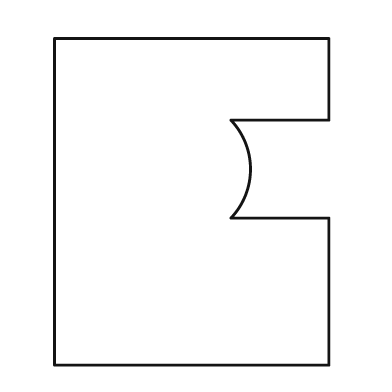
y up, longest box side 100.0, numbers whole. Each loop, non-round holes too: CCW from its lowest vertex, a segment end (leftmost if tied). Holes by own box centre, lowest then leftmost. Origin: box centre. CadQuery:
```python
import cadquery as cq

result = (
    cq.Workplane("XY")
    .moveTo(-42.0, -50.0)
    .lineTo(42.0, -50.0)
    .lineTo(42.0, -5.0)
    .lineTo(12.0, -5.0)
    .threePointArc((18.0, 10.0), (12.0, 25.0))
    .lineTo(42.0, 25.0)
    .lineTo(42.0, 50.0)
    .lineTo(-42.0, 50.0)
    .close()
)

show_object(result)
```